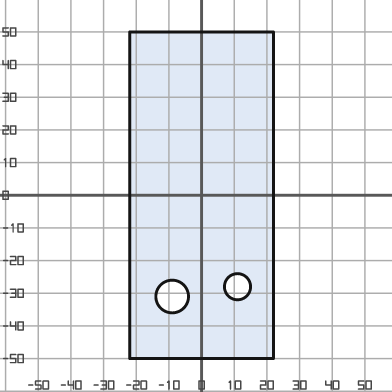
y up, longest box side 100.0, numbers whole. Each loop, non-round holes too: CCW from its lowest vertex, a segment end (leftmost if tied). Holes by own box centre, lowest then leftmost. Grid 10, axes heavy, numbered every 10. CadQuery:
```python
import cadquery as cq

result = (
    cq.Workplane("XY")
    .moveTo(-22.0, -50.0)
    .lineTo(22.0, -50.0)
    .lineTo(22.0, 50.0)
    .lineTo(-22.0, 50.0)
    .close()
    .moveTo(-9.0, -31.0)
    .circle(5.0)
    .moveTo(11.0, -28.0)
    .circle(4.0)
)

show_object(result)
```